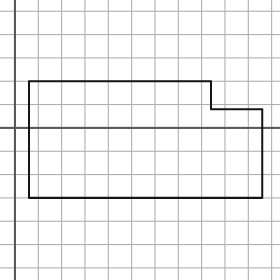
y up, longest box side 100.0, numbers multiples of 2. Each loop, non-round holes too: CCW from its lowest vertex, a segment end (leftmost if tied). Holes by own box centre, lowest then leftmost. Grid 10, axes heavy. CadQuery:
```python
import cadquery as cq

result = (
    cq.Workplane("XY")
    .moveTo(6.0, -30.0)
    .lineTo(106.0, -30.0)
    .lineTo(106.0, 8.0)
    .lineTo(84.0, 8.0)
    .lineTo(84.0, 20.0)
    .lineTo(6.0, 20.0)
    .close()
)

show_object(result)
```